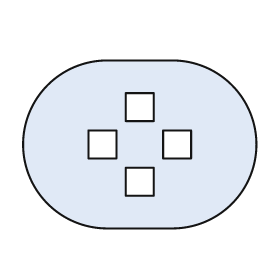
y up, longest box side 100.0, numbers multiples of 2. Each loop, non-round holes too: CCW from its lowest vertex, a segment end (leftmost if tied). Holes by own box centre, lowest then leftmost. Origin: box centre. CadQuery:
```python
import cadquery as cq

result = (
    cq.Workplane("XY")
    .moveTo(-14.0, -36.0)
    .lineTo(14.0, -36.0)
    .threePointArc((50.0, 0.0), (14.0, 36.0))
    .lineTo(-14.0, 36.0)
    .threePointArc((-50.0, 0.0), (-14.0, -36.0))
    .close()
    .moveTo(-6.0, -22.0)
    .lineTo(6.0, -22.0)
    .lineTo(6.0, -10.0)
    .lineTo(-6.0, -10.0)
    .close()
    .moveTo(-22.0, -6.0)
    .lineTo(-10.0, -6.0)
    .lineTo(-10.0, 6.0)
    .lineTo(-22.0, 6.0)
    .close()
    .moveTo(10.0, -6.0)
    .lineTo(22.0, -6.0)
    .lineTo(22.0, 6.0)
    .lineTo(10.0, 6.0)
    .close()
    .moveTo(-6.0, 10.0)
    .lineTo(6.0, 10.0)
    .lineTo(6.0, 22.0)
    .lineTo(-6.0, 22.0)
    .close()
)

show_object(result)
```